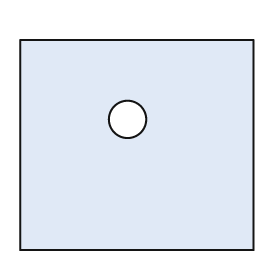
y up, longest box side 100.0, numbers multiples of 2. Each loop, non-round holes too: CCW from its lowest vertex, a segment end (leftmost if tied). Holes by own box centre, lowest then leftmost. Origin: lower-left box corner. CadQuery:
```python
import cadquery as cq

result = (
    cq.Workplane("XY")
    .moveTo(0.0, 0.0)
    .lineTo(100.0, 0.0)
    .lineTo(100.0, 90.0)
    .lineTo(0.0, 90.0)
    .close()
    .moveTo(46.0, 56.0)
    .circle(8.0)
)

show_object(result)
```